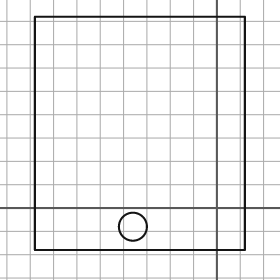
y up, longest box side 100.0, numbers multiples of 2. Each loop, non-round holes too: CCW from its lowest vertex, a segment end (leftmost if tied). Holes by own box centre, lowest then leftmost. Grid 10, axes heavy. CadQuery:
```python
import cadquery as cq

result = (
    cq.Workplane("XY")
    .moveTo(-78.0, -18.0)
    .lineTo(12.0, -18.0)
    .lineTo(12.0, 82.0)
    .lineTo(-78.0, 82.0)
    .close()
    .moveTo(-36.0, -8.0)
    .circle(6.0)
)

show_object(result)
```